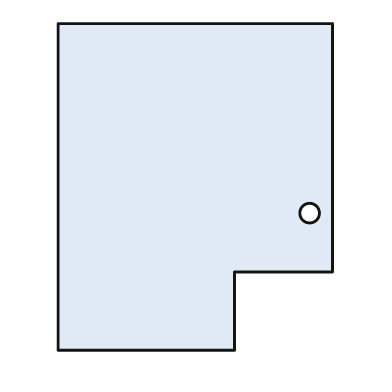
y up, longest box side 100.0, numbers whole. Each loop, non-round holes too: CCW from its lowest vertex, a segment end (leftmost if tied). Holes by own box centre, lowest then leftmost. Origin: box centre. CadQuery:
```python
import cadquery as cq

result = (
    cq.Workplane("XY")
    .moveTo(-42.0, -50.0)
    .lineTo(12.0, -50.0)
    .lineTo(12.0, -26.0)
    .lineTo(42.0, -26.0)
    .lineTo(42.0, 50.0)
    .lineTo(-42.0, 50.0)
    .close()
    .moveTo(35.0, -8.0)
    .circle(3.0)
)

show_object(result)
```